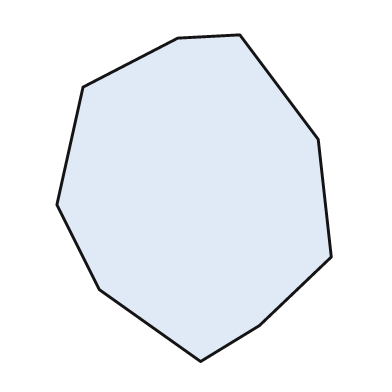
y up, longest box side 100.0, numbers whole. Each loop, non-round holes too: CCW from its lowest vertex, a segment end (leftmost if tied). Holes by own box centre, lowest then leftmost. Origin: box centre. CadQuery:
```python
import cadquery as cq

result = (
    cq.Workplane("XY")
    .moveTo(2.0, -50.0)
    .lineTo(20.0, -39.0)
    .lineTo(42.0, -18.0)
    .lineTo(38.0, 18.0)
    .lineTo(14.0, 50.0)
    .lineTo(-5.0, 49.0)
    .lineTo(-34.0, 34.0)
    .lineTo(-42.0, -2.0)
    .lineTo(-29.0, -28.0)
    .close()
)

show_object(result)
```